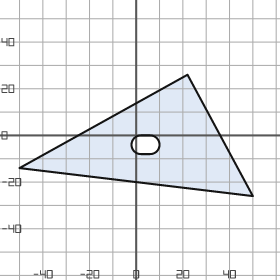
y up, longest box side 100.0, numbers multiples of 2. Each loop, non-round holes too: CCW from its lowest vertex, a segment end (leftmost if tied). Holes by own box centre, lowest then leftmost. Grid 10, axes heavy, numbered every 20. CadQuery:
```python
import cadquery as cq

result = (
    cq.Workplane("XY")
    .moveTo(50.0, -26.0)
    .lineTo(22.0, 26.0)
    .lineTo(-50.0, -14.0)
    .close()
    .moveTo(2.0, -8.0)
    .lineTo(6.0, -8.0)
    .threePointArc((10.0, -4.0), (6.0, 0.0))
    .lineTo(2.0, 0.0)
    .threePointArc((-2.0, -4.0), (2.0, -8.0))
    .close()
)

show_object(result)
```